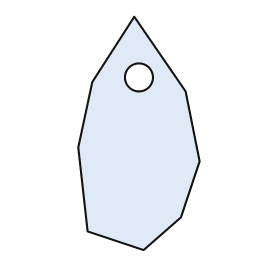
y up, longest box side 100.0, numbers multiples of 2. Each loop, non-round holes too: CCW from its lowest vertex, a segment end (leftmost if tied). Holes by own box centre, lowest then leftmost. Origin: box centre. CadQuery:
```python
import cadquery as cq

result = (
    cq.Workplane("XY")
    .moveTo(2.0, -50.0)
    .lineTo(18.0, -36.0)
    .lineTo(26.0, -12.0)
    .lineTo(20.0, 18.0)
    .lineTo(-2.0, 50.0)
    .lineTo(-20.0, 22.0)
    .lineTo(-26.0, -6.0)
    .lineTo(-22.0, -42.0)
    .close()
    .moveTo(0.0, 24.0)
    .circle(6.0)
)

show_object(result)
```